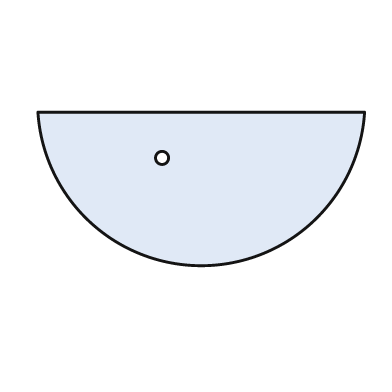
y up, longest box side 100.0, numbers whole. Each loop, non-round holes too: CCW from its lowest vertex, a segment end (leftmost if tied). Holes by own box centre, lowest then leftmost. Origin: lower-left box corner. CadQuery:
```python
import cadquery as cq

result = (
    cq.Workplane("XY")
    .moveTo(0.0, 47.0)
    .threePointArc((50.0, 0.0), (100.0, 47.0))
    .close()
    .moveTo(38.0, 33.0)
    .circle(2.0)
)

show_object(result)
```